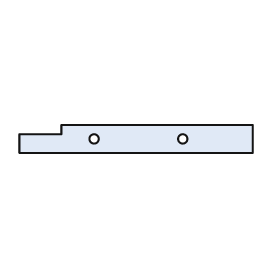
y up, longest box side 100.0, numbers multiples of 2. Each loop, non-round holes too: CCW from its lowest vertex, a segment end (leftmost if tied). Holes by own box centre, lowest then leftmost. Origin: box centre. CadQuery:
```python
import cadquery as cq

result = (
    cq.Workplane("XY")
    .moveTo(-50.0, -6.0)
    .lineTo(50.0, -6.0)
    .lineTo(50.0, 6.0)
    .lineTo(-32.0, 6.0)
    .lineTo(-32.0, 2.0)
    .lineTo(-50.0, 2.0)
    .close()
    .moveTo(-18.0, 0.0)
    .circle(2.0)
    .moveTo(20.0, 0.0)
    .circle(2.0)
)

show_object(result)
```